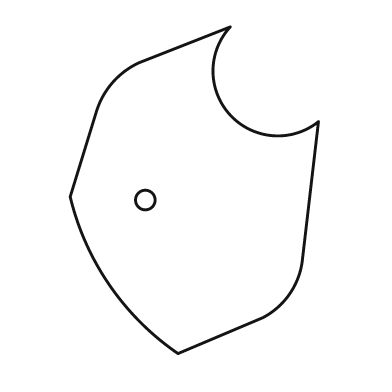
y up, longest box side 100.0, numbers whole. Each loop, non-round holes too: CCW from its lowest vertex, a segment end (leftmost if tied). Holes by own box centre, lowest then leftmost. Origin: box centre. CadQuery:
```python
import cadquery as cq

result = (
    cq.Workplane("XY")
    .moveTo(-5.0, -50.0)
    .lineTo(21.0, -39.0)
    .threePointArc((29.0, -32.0), (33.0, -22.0))
    .lineTo(38.0, 21.0)
    .threePointArc((11.0, 23.0), (11.0, 50.0))
    .lineTo(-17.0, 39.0)
    .threePointArc((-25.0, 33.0), (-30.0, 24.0))
    .lineTo(-38.0, -2.0)
    .threePointArc((-26.0, -29.0), (-5.0, -50.0))
    .close()
    .moveTo(-15.0, -3.0)
    .circle(3.0)
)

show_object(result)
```